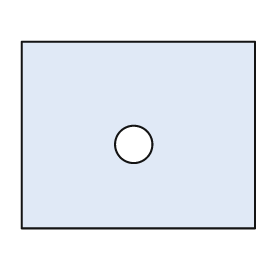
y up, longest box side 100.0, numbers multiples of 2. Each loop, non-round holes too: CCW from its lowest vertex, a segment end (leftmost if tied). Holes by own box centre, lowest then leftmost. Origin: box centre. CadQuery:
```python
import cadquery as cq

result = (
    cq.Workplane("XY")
    .moveTo(-50.0, -40.0)
    .lineTo(50.0, -40.0)
    .lineTo(50.0, 40.0)
    .lineTo(-50.0, 40.0)
    .close()
    .moveTo(-2.0, -4.0)
    .circle(8.0)
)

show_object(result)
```